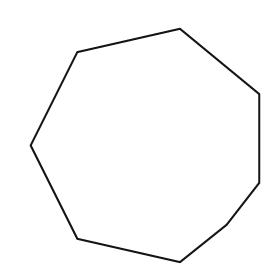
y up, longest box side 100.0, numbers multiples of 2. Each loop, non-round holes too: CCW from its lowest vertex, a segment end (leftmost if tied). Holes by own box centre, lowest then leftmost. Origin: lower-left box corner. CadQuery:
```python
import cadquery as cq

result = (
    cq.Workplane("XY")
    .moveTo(64.0, 0.0)
    .lineTo(84.0, 16.0)
    .lineTo(98.0, 34.0)
    .lineTo(98.0, 72.0)
    .lineTo(64.0, 100.0)
    .lineTo(20.0, 90.0)
    .lineTo(0.0, 50.0)
    .lineTo(20.0, 10.0)
    .close()
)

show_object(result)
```